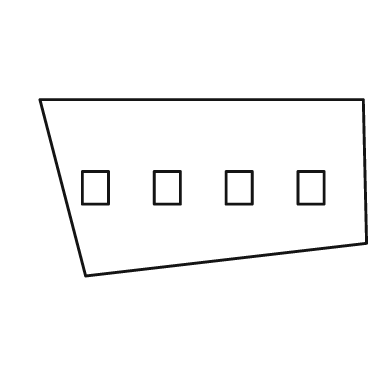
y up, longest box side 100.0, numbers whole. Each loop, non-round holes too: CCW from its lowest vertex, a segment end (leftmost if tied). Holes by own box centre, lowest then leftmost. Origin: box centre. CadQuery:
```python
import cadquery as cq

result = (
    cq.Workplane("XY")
    .moveTo(-36.0, -27.0)
    .lineTo(50.0, -17.0)
    .lineTo(49.0, 27.0)
    .lineTo(-50.0, 27.0)
    .close()
    .moveTo(-37.0, -5.0)
    .lineTo(-29.0, -5.0)
    .lineTo(-29.0, 5.0)
    .lineTo(-37.0, 5.0)
    .close()
    .moveTo(-15.0, -5.0)
    .lineTo(-7.0, -5.0)
    .lineTo(-7.0, 5.0)
    .lineTo(-15.0, 5.0)
    .close()
    .moveTo(7.0, -5.0)
    .lineTo(15.0, -5.0)
    .lineTo(15.0, 5.0)
    .lineTo(7.0, 5.0)
    .close()
    .moveTo(29.0, -5.0)
    .lineTo(37.0, -5.0)
    .lineTo(37.0, 5.0)
    .lineTo(29.0, 5.0)
    .close()
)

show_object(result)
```